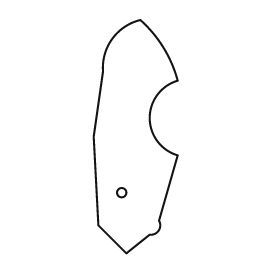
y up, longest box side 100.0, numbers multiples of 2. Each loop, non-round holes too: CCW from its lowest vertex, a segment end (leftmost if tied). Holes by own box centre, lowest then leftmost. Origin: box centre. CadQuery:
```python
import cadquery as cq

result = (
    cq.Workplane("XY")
    .moveTo(-4.0, -50.0)
    .lineTo(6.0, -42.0)
    .threePointArc((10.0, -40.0), (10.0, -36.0))
    .lineTo(18.0, -8.0)
    .threePointArc((6.0, 8.0), (18.0, 24.0))
    .threePointArc((12.0, 38.0), (2.0, 50.0))
    .threePointArc((-10.0, 42.0), (-14.0, 28.0))
    .lineTo(-18.0, 0.0)
    .lineTo(-16.0, -38.0)
    .close()
    .moveTo(-6.0, -24.0)
    .circle(2.0)
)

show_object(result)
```